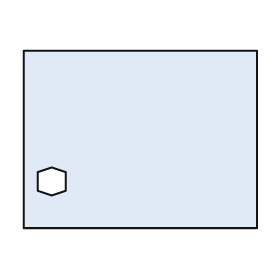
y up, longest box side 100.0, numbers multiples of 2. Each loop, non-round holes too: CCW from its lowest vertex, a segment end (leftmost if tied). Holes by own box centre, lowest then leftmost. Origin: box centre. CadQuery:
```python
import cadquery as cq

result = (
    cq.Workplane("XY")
    .moveTo(-50.0, -38.0)
    .lineTo(50.0, -38.0)
    .lineTo(50.0, 38.0)
    .lineTo(-50.0, 38.0)
    .close()
    .moveTo(-38.0, -24.0)
    .lineTo(-32.0, -22.0)
    .lineTo(-32.0, -14.0)
    .lineTo(-38.0, -12.0)
    .lineTo(-44.0, -14.0)
    .lineTo(-44.0, -22.0)
    .close()
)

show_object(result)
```